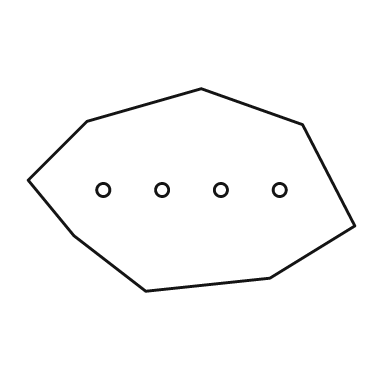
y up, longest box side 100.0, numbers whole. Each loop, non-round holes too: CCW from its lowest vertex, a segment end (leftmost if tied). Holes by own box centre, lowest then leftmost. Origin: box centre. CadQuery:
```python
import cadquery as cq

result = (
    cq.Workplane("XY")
    .moveTo(-14.0, -31.0)
    .lineTo(24.0, -27.0)
    .lineTo(50.0, -11.0)
    .lineTo(34.0, 20.0)
    .lineTo(3.0, 31.0)
    .lineTo(-32.0, 21.0)
    .lineTo(-50.0, 3.0)
    .lineTo(-36.0, -14.0)
    .close()
    .moveTo(-27.0, 0.0)
    .circle(2.0)
    .moveTo(-9.0, 0.0)
    .circle(2.0)
    .moveTo(9.0, 0.0)
    .circle(2.0)
    .moveTo(27.0, 0.0)
    .circle(2.0)
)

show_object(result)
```